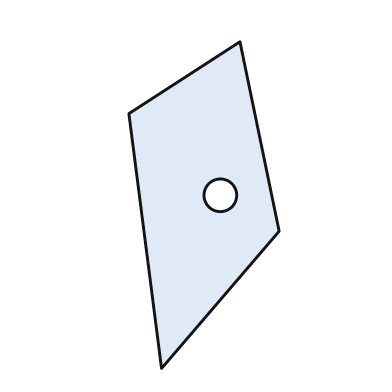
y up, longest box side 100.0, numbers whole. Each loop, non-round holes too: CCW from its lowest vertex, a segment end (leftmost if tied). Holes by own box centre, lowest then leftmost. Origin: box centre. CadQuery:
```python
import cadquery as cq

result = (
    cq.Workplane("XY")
    .moveTo(-13.0, -50.0)
    .lineTo(23.0, -8.0)
    .lineTo(11.0, 50.0)
    .lineTo(-23.0, 28.0)
    .close()
    .moveTo(5.0, 3.0)
    .circle(5.0)
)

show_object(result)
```